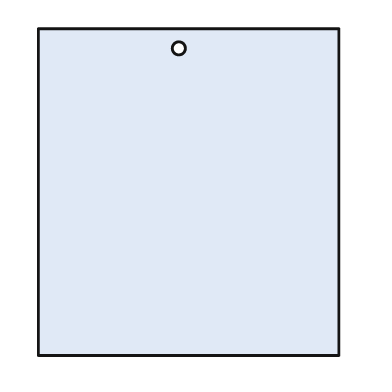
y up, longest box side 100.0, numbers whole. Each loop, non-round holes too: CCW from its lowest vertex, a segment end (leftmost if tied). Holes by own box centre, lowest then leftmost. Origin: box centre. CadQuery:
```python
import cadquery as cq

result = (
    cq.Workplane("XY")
    .moveTo(-46.0, -50.0)
    .lineTo(46.0, -50.0)
    .lineTo(46.0, 50.0)
    .lineTo(-46.0, 50.0)
    .close()
    .moveTo(-3.0, 44.0)
    .circle(2.0)
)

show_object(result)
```